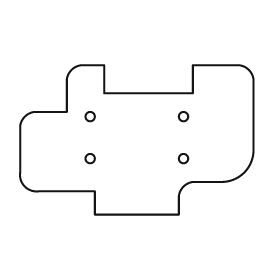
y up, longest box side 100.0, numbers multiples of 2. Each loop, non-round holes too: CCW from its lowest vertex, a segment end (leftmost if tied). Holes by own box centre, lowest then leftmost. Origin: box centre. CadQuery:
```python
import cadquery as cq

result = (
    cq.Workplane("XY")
    .moveTo(-18.0, -32.0)
    .lineTo(18.0, -32.0)
    .lineTo(18.0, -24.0)
    .threePointArc((20.0, -20.0), (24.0, -18.0))
    .lineTo(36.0, -18.0)
    .threePointArc((46.0, -14.0), (50.0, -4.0))
    .lineTo(50.0, 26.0)
    .threePointArc((48.0, 30.0), (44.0, 32.0))
    .lineTo(24.0, 32.0)
    .lineTo(24.0, 20.0)
    .lineTo(-14.0, 20.0)
    .lineTo(-14.0, 32.0)
    .lineTo(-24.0, 32.0)
    .threePointArc((-28.0, 30.0), (-30.0, 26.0))
    .lineTo(-30.0, 12.0)
    .lineTo(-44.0, 12.0)
    .threePointArc((-48.0, 10.0), (-50.0, 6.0))
    .lineTo(-50.0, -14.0)
    .threePointArc((-48.0, -20.0), (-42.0, -22.0))
    .lineTo(-18.0, -22.0)
    .close()
    .moveTo(-20.0, -8.0)
    .circle(2.0)
    .moveTo(20.0, -8.0)
    .circle(2.0)
    .moveTo(-20.0, 10.0)
    .circle(2.0)
    .moveTo(20.0, 10.0)
    .circle(2.0)
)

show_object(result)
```